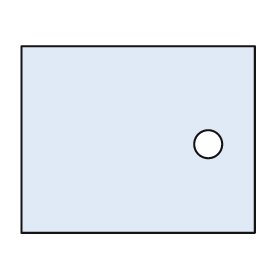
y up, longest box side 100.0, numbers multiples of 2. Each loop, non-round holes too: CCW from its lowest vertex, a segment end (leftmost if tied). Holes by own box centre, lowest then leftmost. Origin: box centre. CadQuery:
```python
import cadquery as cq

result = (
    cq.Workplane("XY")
    .moveTo(-50.0, -40.0)
    .lineTo(50.0, -40.0)
    .lineTo(50.0, 40.0)
    .lineTo(-50.0, 40.0)
    .close()
    .moveTo(30.0, -2.0)
    .circle(6.0)
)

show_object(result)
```